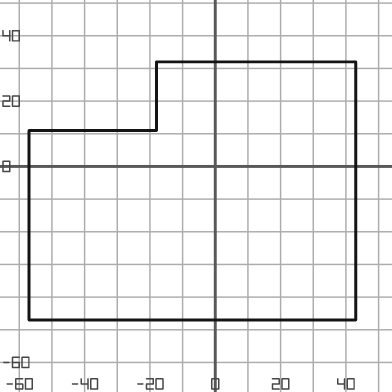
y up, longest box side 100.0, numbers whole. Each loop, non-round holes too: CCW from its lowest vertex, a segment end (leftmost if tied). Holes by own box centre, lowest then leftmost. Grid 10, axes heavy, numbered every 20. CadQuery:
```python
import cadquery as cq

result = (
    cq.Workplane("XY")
    .moveTo(-57.0, -47.0)
    .lineTo(43.0, -47.0)
    .lineTo(43.0, 32.0)
    .lineTo(-18.0, 32.0)
    .lineTo(-18.0, 11.0)
    .lineTo(-57.0, 11.0)
    .close()
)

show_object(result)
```